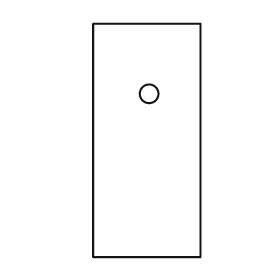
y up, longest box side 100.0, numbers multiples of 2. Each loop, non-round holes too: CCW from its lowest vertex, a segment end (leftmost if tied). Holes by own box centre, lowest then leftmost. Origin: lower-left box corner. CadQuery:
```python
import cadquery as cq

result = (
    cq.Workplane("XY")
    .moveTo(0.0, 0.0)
    .lineTo(46.0, 0.0)
    .lineTo(46.0, 100.0)
    .lineTo(0.0, 100.0)
    .close()
    .moveTo(24.0, 70.0)
    .circle(4.0)
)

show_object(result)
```